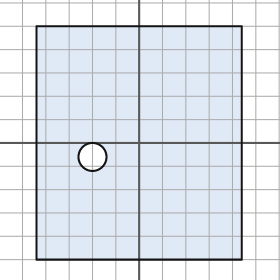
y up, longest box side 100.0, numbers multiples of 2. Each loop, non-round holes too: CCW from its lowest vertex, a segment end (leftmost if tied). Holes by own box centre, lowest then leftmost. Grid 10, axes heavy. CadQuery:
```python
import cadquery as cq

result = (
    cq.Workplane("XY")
    .moveTo(-44.0, -50.0)
    .lineTo(44.0, -50.0)
    .lineTo(44.0, 50.0)
    .lineTo(-44.0, 50.0)
    .close()
    .moveTo(-20.0, -6.0)
    .circle(6.0)
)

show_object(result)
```